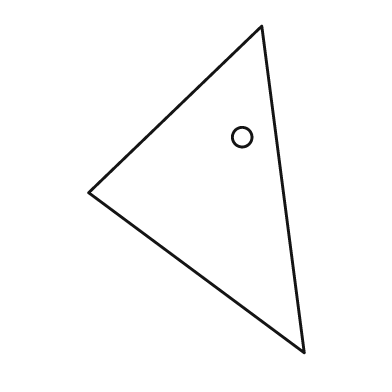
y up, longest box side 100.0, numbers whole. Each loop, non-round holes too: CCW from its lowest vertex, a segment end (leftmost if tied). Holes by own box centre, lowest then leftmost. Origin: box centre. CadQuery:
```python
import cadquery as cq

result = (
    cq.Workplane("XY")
    .moveTo(33.0, -50.0)
    .lineTo(20.0, 50.0)
    .lineTo(-33.0, -1.0)
    .close()
    .moveTo(14.0, 16.0)
    .circle(3.0)
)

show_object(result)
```